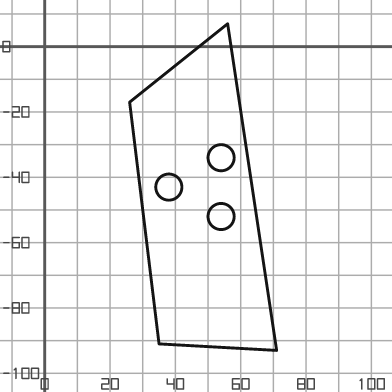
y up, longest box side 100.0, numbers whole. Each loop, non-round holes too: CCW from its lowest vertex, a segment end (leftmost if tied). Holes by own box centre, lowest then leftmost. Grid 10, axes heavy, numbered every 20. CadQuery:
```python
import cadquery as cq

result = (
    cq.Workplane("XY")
    .moveTo(71.0, -93.0)
    .lineTo(56.0, 7.0)
    .lineTo(26.0, -17.0)
    .lineTo(35.0, -91.0)
    .close()
    .moveTo(54.0, -52.0)
    .circle(4.0)
    .moveTo(38.0, -43.0)
    .circle(4.0)
    .moveTo(54.0, -34.0)
    .circle(4.0)
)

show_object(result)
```